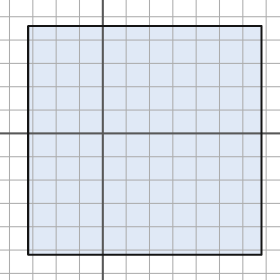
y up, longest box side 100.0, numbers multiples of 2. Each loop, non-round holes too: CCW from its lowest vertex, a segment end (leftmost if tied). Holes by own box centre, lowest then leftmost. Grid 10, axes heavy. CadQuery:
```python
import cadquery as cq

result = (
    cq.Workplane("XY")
    .moveTo(-32.0, -52.0)
    .lineTo(68.0, -52.0)
    .lineTo(68.0, 46.0)
    .lineTo(-32.0, 46.0)
    .close()
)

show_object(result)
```